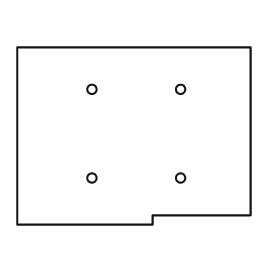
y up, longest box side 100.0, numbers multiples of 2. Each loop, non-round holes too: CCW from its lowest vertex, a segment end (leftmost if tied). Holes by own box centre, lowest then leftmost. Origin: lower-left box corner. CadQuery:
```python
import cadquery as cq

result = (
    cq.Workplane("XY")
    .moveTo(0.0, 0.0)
    .lineTo(58.0, 0.0)
    .lineTo(58.0, 4.0)
    .lineTo(100.0, 4.0)
    .lineTo(100.0, 76.0)
    .lineTo(0.0, 76.0)
    .close()
    .moveTo(32.0, 20.0)
    .circle(2.0)
    .moveTo(70.0, 20.0)
    .circle(2.0)
    .moveTo(32.0, 58.0)
    .circle(2.0)
    .moveTo(70.0, 58.0)
    .circle(2.0)
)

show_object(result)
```